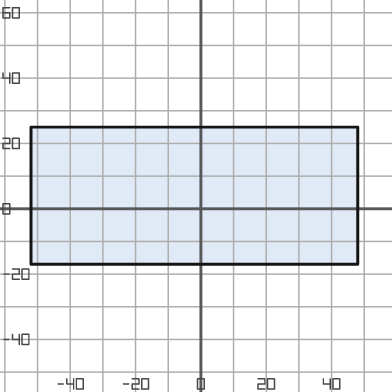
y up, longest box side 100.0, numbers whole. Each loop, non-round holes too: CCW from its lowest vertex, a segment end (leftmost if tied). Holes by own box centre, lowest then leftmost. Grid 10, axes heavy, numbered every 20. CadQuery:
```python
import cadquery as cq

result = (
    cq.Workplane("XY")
    .moveTo(-52.0, -17.0)
    .lineTo(48.0, -17.0)
    .lineTo(48.0, 25.0)
    .lineTo(-52.0, 25.0)
    .close()
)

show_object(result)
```